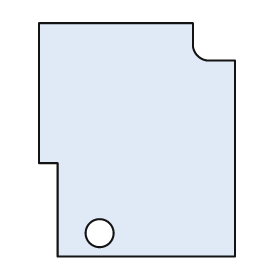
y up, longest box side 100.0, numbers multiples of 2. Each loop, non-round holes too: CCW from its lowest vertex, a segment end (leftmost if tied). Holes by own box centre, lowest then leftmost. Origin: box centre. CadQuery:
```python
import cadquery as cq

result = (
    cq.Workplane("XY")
    .moveTo(-34.0, -50.0)
    .lineTo(42.0, -50.0)
    .lineTo(42.0, 34.0)
    .lineTo(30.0, 34.0)
    .threePointArc((26.0, 36.0), (24.0, 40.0))
    .lineTo(24.0, 50.0)
    .lineTo(-42.0, 50.0)
    .lineTo(-42.0, -10.0)
    .lineTo(-34.0, -10.0)
    .close()
    .moveTo(-16.0, -40.0)
    .circle(6.0)
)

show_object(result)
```